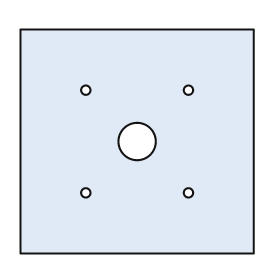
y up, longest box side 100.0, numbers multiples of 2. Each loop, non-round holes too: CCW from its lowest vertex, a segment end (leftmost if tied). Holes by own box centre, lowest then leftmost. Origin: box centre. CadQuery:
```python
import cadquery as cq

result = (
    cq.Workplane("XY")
    .moveTo(-50.0, -48.0)
    .lineTo(50.0, -48.0)
    .lineTo(50.0, 48.0)
    .lineTo(-50.0, 48.0)
    .close()
    .moveTo(-22.0, -22.0)
    .circle(2.0)
    .moveTo(22.0, -22.0)
    .circle(2.0)
    .moveTo(0.0, 0.0)
    .circle(8.0)
    .moveTo(-22.0, 22.0)
    .circle(2.0)
    .moveTo(22.0, 22.0)
    .circle(2.0)
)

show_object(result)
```